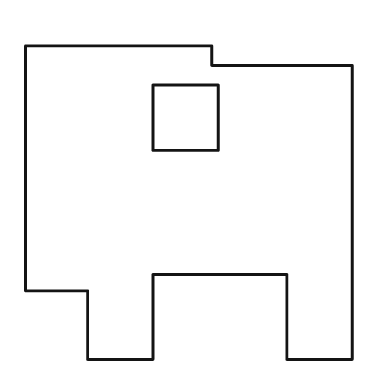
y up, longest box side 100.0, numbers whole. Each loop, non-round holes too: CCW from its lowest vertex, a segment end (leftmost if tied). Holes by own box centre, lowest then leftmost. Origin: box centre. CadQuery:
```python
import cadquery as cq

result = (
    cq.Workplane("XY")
    .moveTo(-31.0, -48.0)
    .lineTo(-11.0, -48.0)
    .lineTo(-11.0, -22.0)
    .lineTo(30.0, -22.0)
    .lineTo(30.0, -48.0)
    .lineTo(50.0, -48.0)
    .lineTo(50.0, 42.0)
    .lineTo(7.0, 42.0)
    .lineTo(7.0, 48.0)
    .lineTo(-50.0, 48.0)
    .lineTo(-50.0, -27.0)
    .lineTo(-31.0, -27.0)
    .close()
    .moveTo(-11.0, 16.0)
    .lineTo(9.0, 16.0)
    .lineTo(9.0, 36.0)
    .lineTo(-11.0, 36.0)
    .close()
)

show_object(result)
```